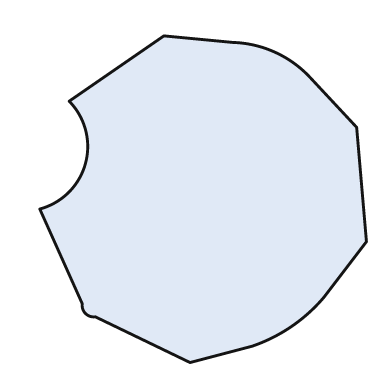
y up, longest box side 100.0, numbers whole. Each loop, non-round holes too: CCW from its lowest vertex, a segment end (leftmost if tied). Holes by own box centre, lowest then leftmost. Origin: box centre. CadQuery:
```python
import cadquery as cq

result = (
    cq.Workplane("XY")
    .moveTo(-4.0, -50.0)
    .lineTo(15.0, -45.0)
    .threePointArc((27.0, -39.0), (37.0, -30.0))
    .lineTo(50.0, -13.0)
    .lineTo(47.0, 22.0)
    .lineTo(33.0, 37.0)
    .threePointArc((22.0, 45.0), (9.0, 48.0))
    .lineTo(-12.0, 50.0)
    .lineTo(-41.0, 30.0)
    .threePointArc((-36.0, 11.0), (-50.0, -3.0))
    .lineTo(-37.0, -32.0)
    .threePointArc((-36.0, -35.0), (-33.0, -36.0))
    .close()
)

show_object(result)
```